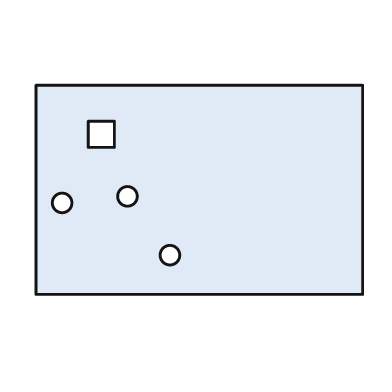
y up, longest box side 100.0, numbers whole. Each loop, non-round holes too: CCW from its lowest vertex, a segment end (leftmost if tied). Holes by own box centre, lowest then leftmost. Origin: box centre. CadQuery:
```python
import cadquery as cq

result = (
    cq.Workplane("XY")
    .moveTo(-50.0, -32.0)
    .lineTo(50.0, -32.0)
    .lineTo(50.0, 32.0)
    .lineTo(-50.0, 32.0)
    .close()
    .moveTo(-9.0, -20.0)
    .circle(3.0)
    .moveTo(-42.0, -4.0)
    .circle(3.0)
    .moveTo(-22.0, -2.0)
    .circle(3.0)
    .moveTo(-34.0, 13.0)
    .lineTo(-26.0, 13.0)
    .lineTo(-26.0, 21.0)
    .lineTo(-34.0, 21.0)
    .close()
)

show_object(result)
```